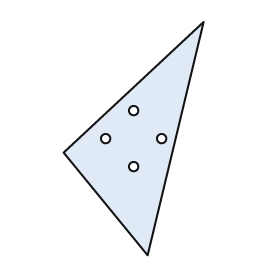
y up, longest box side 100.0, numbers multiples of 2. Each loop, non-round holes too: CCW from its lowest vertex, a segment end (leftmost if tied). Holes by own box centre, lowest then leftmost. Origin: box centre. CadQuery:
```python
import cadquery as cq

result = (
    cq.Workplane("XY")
    .moveTo(6.0, -50.0)
    .lineTo(30.0, 50.0)
    .lineTo(-30.0, -6.0)
    .close()
    .moveTo(0.0, -12.0)
    .circle(2.0)
    .moveTo(-12.0, 0.0)
    .circle(2.0)
    .moveTo(12.0, 0.0)
    .circle(2.0)
    .moveTo(0.0, 12.0)
    .circle(2.0)
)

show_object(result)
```